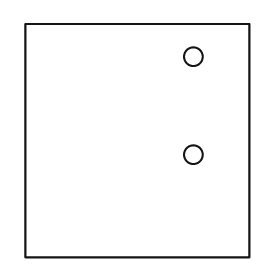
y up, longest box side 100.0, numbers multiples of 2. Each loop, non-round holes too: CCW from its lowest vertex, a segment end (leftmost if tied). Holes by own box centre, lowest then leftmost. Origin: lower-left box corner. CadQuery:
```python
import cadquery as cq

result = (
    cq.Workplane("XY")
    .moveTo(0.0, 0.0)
    .lineTo(96.0, 0.0)
    .lineTo(96.0, 100.0)
    .lineTo(0.0, 100.0)
    .close()
    .moveTo(72.0, 44.0)
    .circle(4.0)
    .moveTo(72.0, 86.0)
    .circle(4.0)
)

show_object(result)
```